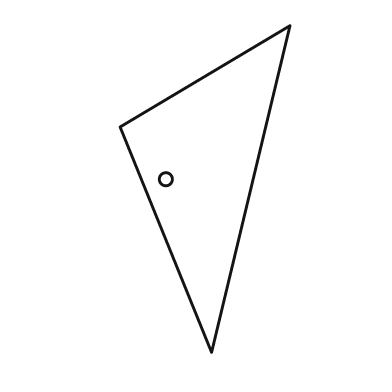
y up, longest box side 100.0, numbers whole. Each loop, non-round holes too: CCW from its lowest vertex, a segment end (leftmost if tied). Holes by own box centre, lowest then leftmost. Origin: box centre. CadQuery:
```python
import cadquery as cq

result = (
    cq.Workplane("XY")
    .moveTo(2.0, -50.0)
    .lineTo(26.0, 50.0)
    .lineTo(-26.0, 19.0)
    .close()
    .moveTo(-12.0, 3.0)
    .circle(2.0)
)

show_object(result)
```